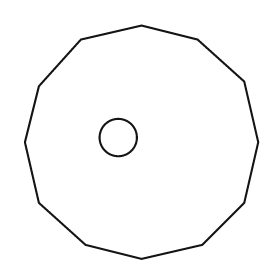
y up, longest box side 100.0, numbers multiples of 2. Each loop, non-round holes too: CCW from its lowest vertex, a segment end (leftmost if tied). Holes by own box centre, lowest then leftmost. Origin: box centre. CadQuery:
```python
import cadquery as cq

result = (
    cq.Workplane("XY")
    .moveTo(0.0, -50.0)
    .lineTo(26.0, -44.0)
    .lineTo(44.0, -26.0)
    .lineTo(50.0, 0.0)
    .lineTo(44.0, 26.0)
    .lineTo(24.0, 44.0)
    .lineTo(0.0, 50.0)
    .lineTo(-26.0, 44.0)
    .lineTo(-44.0, 24.0)
    .lineTo(-50.0, 0.0)
    .lineTo(-44.0, -26.0)
    .lineTo(-24.0, -44.0)
    .close()
    .moveTo(-10.0, 2.0)
    .circle(8.0)
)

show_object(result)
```